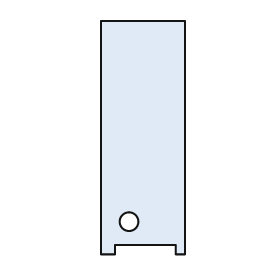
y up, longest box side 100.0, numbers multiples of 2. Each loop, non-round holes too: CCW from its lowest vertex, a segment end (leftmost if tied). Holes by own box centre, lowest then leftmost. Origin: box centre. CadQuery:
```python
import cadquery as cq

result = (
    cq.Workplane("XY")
    .moveTo(-18.0, -50.0)
    .lineTo(-12.0, -50.0)
    .lineTo(-12.0, -46.0)
    .lineTo(14.0, -46.0)
    .lineTo(14.0, -50.0)
    .lineTo(18.0, -50.0)
    .lineTo(18.0, 50.0)
    .lineTo(-18.0, 50.0)
    .close()
    .moveTo(-6.0, -36.0)
    .circle(4.0)
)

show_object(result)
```